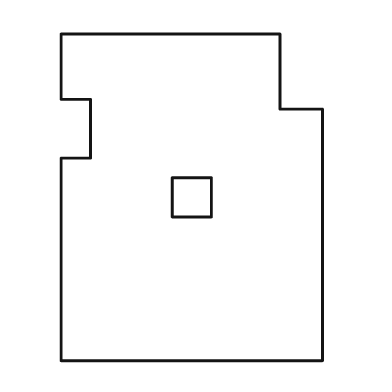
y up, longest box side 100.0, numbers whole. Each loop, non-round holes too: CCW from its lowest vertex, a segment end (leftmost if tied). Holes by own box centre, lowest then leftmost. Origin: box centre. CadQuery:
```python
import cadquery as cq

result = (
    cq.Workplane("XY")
    .moveTo(-40.0, -50.0)
    .lineTo(40.0, -50.0)
    .lineTo(40.0, 27.0)
    .lineTo(27.0, 27.0)
    .lineTo(27.0, 50.0)
    .lineTo(-40.0, 50.0)
    .lineTo(-40.0, 30.0)
    .lineTo(-31.0, 30.0)
    .lineTo(-31.0, 12.0)
    .lineTo(-40.0, 12.0)
    .close()
    .moveTo(-6.0, -6.0)
    .lineTo(6.0, -6.0)
    .lineTo(6.0, 6.0)
    .lineTo(-6.0, 6.0)
    .close()
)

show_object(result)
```